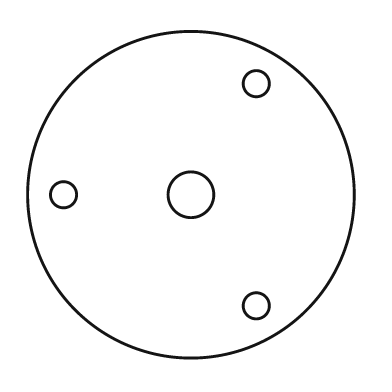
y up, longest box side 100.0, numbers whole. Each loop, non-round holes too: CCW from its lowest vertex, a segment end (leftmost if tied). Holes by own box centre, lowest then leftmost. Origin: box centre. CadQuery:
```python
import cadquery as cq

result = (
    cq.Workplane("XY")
    .moveTo(0.0, 0.0)
    .circle(50.0)
    .moveTo(20.0, -34.0)
    .circle(4.0)
    .moveTo(-39.0, 0.0)
    .circle(4.0)
    .moveTo(0.0, 0.0)
    .circle(7.0)
    .moveTo(20.0, 34.0)
    .circle(4.0)
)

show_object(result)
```